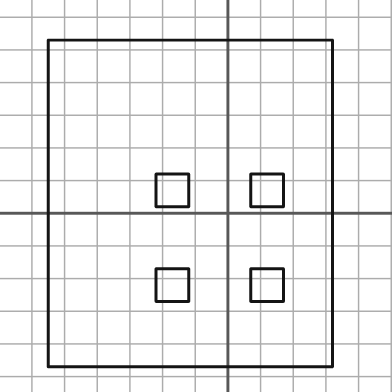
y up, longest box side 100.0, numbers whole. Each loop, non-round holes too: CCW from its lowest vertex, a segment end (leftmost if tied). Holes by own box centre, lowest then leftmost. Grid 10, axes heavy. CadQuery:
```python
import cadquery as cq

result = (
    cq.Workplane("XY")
    .moveTo(-55.0, -47.0)
    .lineTo(32.0, -47.0)
    .lineTo(32.0, 53.0)
    .lineTo(-55.0, 53.0)
    .close()
    .moveTo(-22.0, -27.0)
    .lineTo(-12.0, -27.0)
    .lineTo(-12.0, -17.0)
    .lineTo(-22.0, -17.0)
    .close()
    .moveTo(7.0, -27.0)
    .lineTo(17.0, -27.0)
    .lineTo(17.0, -17.0)
    .lineTo(7.0, -17.0)
    .close()
    .moveTo(-22.0, 2.0)
    .lineTo(-12.0, 2.0)
    .lineTo(-12.0, 12.0)
    .lineTo(-22.0, 12.0)
    .close()
    .moveTo(7.0, 2.0)
    .lineTo(17.0, 2.0)
    .lineTo(17.0, 12.0)
    .lineTo(7.0, 12.0)
    .close()
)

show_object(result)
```